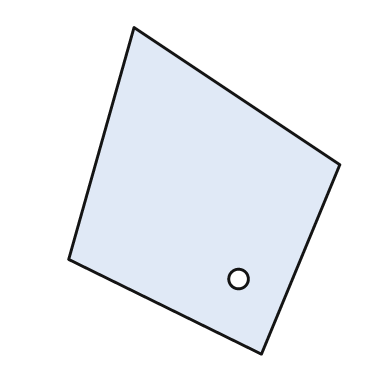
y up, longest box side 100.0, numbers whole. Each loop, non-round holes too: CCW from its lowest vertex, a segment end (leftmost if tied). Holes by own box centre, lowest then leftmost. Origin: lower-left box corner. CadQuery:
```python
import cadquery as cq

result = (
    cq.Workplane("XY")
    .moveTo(59.0, 0.0)
    .lineTo(83.0, 58.0)
    .lineTo(20.0, 100.0)
    .lineTo(0.0, 29.0)
    .close()
    .moveTo(52.0, 23.0)
    .circle(3.0)
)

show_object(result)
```